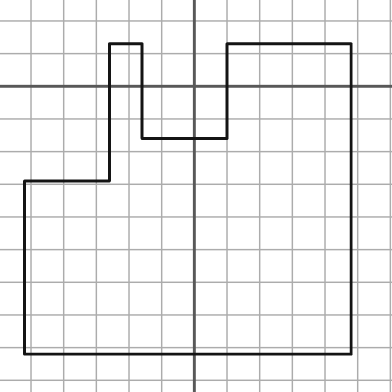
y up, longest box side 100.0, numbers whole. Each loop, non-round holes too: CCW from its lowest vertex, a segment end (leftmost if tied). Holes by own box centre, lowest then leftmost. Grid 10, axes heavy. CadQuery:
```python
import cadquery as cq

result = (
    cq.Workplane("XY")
    .moveTo(-52.0, -82.0)
    .lineTo(48.0, -82.0)
    .lineTo(48.0, 13.0)
    .lineTo(10.0, 13.0)
    .lineTo(10.0, -16.0)
    .lineTo(-16.0, -16.0)
    .lineTo(-16.0, 13.0)
    .lineTo(-26.0, 13.0)
    .lineTo(-26.0, -29.0)
    .lineTo(-52.0, -29.0)
    .close()
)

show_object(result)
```